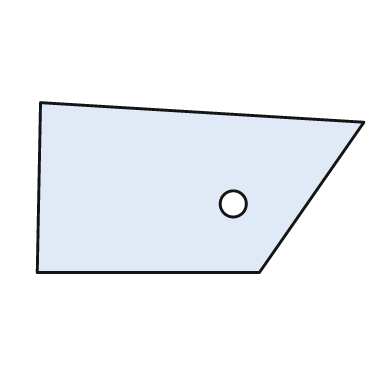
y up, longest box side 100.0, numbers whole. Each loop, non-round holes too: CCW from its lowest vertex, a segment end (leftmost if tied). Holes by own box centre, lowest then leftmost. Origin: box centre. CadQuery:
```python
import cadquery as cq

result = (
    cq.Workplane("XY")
    .moveTo(-50.0, -26.0)
    .lineTo(18.0, -26.0)
    .lineTo(50.0, 20.0)
    .lineTo(-49.0, 26.0)
    .close()
    .moveTo(10.0, -5.0)
    .circle(4.0)
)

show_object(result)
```